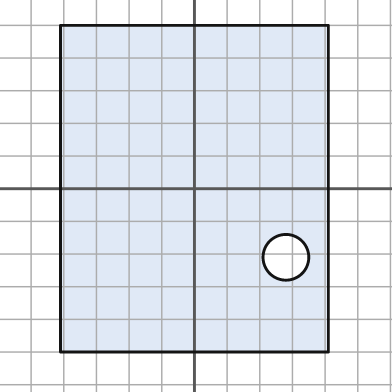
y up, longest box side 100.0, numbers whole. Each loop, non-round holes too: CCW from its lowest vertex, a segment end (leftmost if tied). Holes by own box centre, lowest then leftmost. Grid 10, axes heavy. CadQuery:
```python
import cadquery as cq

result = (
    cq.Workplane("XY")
    .moveTo(-41.0, -50.0)
    .lineTo(41.0, -50.0)
    .lineTo(41.0, 50.0)
    .lineTo(-41.0, 50.0)
    .close()
    .moveTo(28.0, -21.0)
    .circle(7.0)
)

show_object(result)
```